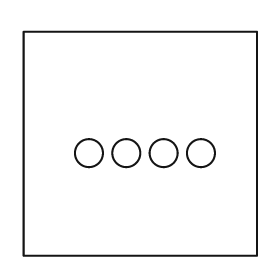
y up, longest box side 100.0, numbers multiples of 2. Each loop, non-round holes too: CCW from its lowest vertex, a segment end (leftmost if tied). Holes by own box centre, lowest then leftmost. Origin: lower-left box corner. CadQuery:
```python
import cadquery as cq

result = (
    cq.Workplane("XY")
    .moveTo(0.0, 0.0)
    .lineTo(100.0, 0.0)
    .lineTo(100.0, 96.0)
    .lineTo(0.0, 96.0)
    .close()
    .moveTo(28.0, 44.0)
    .circle(6.0)
    .moveTo(44.0, 44.0)
    .circle(6.0)
    .moveTo(60.0, 44.0)
    .circle(6.0)
    .moveTo(76.0, 44.0)
    .circle(6.0)
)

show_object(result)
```